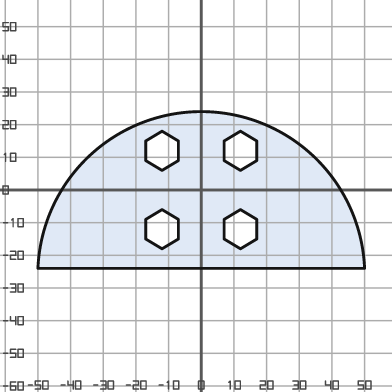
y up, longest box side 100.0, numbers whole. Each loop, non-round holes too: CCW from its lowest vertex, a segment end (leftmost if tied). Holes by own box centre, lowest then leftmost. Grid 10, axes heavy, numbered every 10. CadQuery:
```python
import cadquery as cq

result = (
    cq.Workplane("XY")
    .moveTo(-50.0, -24.0)
    .lineTo(50.0, -24.0)
    .threePointArc((0.0, 24.0), (-50.0, -24.0))
    .close()
    .moveTo(-12.0, -18.0)
    .lineTo(-7.0, -15.0)
    .lineTo(-7.0, -9.0)
    .lineTo(-12.0, -6.0)
    .lineTo(-17.0, -9.0)
    .lineTo(-17.0, -15.0)
    .close()
    .moveTo(12.0, -18.0)
    .lineTo(17.0, -15.0)
    .lineTo(17.0, -9.0)
    .lineTo(12.0, -6.0)
    .lineTo(7.0, -9.0)
    .lineTo(7.0, -15.0)
    .close()
    .moveTo(-12.0, 6.0)
    .lineTo(-7.0, 9.0)
    .lineTo(-7.0, 15.0)
    .lineTo(-12.0, 18.0)
    .lineTo(-17.0, 15.0)
    .lineTo(-17.0, 9.0)
    .close()
    .moveTo(12.0, 6.0)
    .lineTo(17.0, 9.0)
    .lineTo(17.0, 15.0)
    .lineTo(12.0, 18.0)
    .lineTo(7.0, 15.0)
    .lineTo(7.0, 9.0)
    .close()
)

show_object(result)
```